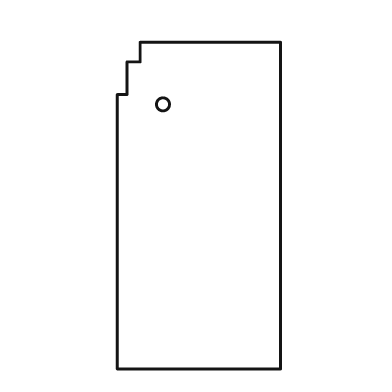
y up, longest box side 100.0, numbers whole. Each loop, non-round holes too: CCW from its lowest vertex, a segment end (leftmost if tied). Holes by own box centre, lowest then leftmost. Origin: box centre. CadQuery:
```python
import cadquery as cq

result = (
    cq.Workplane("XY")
    .moveTo(-25.0, -50.0)
    .lineTo(25.0, -50.0)
    .lineTo(25.0, 50.0)
    .lineTo(-18.0, 50.0)
    .lineTo(-18.0, 44.0)
    .lineTo(-22.0, 44.0)
    .lineTo(-22.0, 34.0)
    .lineTo(-25.0, 34.0)
    .close()
    .moveTo(-11.0, 31.0)
    .circle(2.0)
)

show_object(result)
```